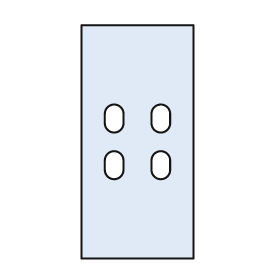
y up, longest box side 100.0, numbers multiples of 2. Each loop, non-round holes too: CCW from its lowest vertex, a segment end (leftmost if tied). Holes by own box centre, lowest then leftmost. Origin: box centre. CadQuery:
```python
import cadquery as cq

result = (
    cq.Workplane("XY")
    .moveTo(-24.0, -50.0)
    .lineTo(24.0, -50.0)
    .lineTo(24.0, 50.0)
    .lineTo(-24.0, 50.0)
    .close()
    .moveTo(-14.0, -12.0)
    .threePointArc((-10.0, -16.0), (-6.0, -12.0))
    .lineTo(-6.0, -8.0)
    .threePointArc((-10.0, -4.0), (-14.0, -8.0))
    .close()
    .moveTo(6.0, -12.0)
    .threePointArc((10.0, -16.0), (14.0, -12.0))
    .lineTo(14.0, -8.0)
    .threePointArc((10.0, -4.0), (6.0, -8.0))
    .close()
    .moveTo(-14.0, 8.0)
    .threePointArc((-10.0, 4.0), (-6.0, 8.0))
    .lineTo(-6.0, 12.0)
    .threePointArc((-10.0, 16.0), (-14.0, 12.0))
    .close()
    .moveTo(6.0, 8.0)
    .threePointArc((10.0, 4.0), (14.0, 8.0))
    .lineTo(14.0, 12.0)
    .threePointArc((10.0, 16.0), (6.0, 12.0))
    .close()
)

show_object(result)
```